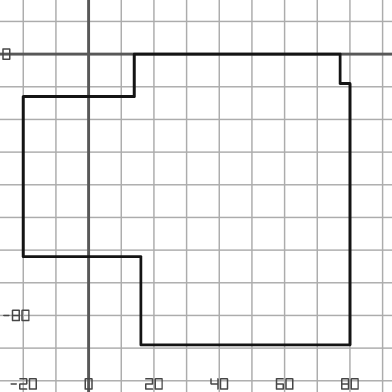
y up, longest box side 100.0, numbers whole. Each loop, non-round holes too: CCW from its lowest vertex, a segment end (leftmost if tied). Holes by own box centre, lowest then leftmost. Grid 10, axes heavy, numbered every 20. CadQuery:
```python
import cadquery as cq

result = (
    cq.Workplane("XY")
    .moveTo(16.0, -89.0)
    .lineTo(80.0, -89.0)
    .lineTo(80.0, -9.0)
    .lineTo(77.0, -9.0)
    .lineTo(77.0, 0.0)
    .lineTo(14.0, 0.0)
    .lineTo(14.0, -13.0)
    .lineTo(-20.0, -13.0)
    .lineTo(-20.0, -62.0)
    .lineTo(16.0, -62.0)
    .close()
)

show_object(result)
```